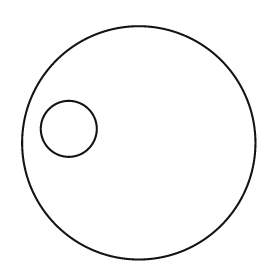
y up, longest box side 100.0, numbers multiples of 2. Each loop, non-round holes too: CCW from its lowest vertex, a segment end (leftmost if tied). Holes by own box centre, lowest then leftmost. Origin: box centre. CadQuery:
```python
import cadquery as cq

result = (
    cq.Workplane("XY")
    .moveTo(0.0, 0.0)
    .circle(50.0)
    .moveTo(-30.0, 6.0)
    .circle(12.0)
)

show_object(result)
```